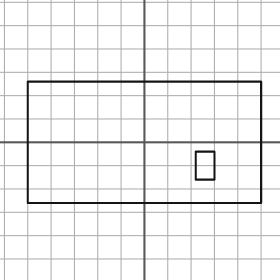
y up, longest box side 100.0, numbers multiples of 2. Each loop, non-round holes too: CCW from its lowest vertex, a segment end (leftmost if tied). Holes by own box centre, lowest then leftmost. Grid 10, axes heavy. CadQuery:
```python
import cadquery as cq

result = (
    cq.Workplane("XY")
    .moveTo(-50.0, -26.0)
    .lineTo(50.0, -26.0)
    .lineTo(50.0, 26.0)
    .lineTo(-50.0, 26.0)
    .close()
    .moveTo(22.0, -16.0)
    .lineTo(30.0, -16.0)
    .lineTo(30.0, -4.0)
    .lineTo(22.0, -4.0)
    .close()
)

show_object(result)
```